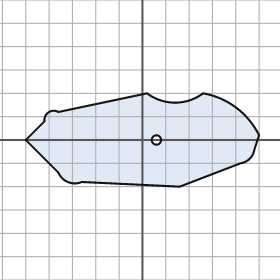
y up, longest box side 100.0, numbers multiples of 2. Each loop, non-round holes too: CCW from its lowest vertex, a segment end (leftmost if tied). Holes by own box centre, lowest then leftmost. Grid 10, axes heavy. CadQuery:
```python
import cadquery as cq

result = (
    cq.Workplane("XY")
    .moveTo(16.0, -20.0)
    .lineTo(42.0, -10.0)
    .threePointArc((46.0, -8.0), (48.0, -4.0))
    .lineTo(50.0, 2.0)
    .threePointArc((40.0, 14.0), (26.0, 20.0))
    .threePointArc((14.0, 16.0), (2.0, 20.0))
    .lineTo(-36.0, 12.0)
    .threePointArc((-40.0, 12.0), (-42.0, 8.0))
    .lineTo(-50.0, 0.0)
    .lineTo(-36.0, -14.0)
    .threePointArc((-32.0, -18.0), (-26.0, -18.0))
    .close()
    .moveTo(6.0, 0.0)
    .circle(2.0)
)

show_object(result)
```